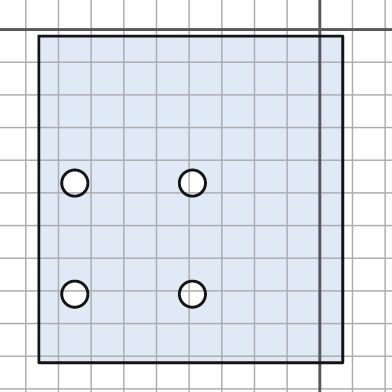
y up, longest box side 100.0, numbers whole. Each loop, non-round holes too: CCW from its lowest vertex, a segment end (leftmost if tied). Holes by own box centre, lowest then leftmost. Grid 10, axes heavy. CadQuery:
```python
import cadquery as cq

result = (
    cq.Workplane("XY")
    .moveTo(-86.0, -102.0)
    .lineTo(7.0, -102.0)
    .lineTo(7.0, -2.0)
    .lineTo(-86.0, -2.0)
    .close()
    .moveTo(-75.0, -81.0)
    .circle(4.0)
    .moveTo(-39.0, -81.0)
    .circle(4.0)
    .moveTo(-75.0, -47.0)
    .circle(4.0)
    .moveTo(-39.0, -47.0)
    .circle(4.0)
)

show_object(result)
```